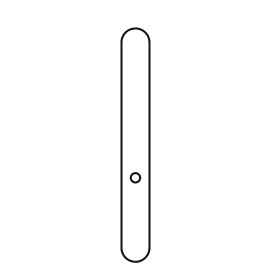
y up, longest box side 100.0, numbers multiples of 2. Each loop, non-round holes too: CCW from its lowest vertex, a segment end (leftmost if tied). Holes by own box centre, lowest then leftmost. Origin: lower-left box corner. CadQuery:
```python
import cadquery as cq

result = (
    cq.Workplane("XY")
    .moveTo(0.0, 6.0)
    .threePointArc((6.0, 0.0), (12.0, 6.0))
    .lineTo(12.0, 94.0)
    .threePointArc((6.0, 100.0), (0.0, 94.0))
    .close()
    .moveTo(6.0, 36.0)
    .circle(2.0)
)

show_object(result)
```